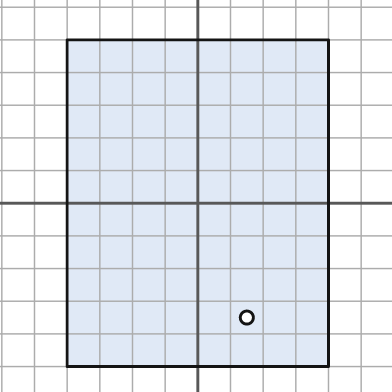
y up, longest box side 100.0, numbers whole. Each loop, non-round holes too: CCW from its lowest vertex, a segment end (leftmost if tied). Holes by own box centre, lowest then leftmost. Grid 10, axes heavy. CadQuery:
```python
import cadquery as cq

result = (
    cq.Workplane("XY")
    .moveTo(-40.0, -50.0)
    .lineTo(40.0, -50.0)
    .lineTo(40.0, 50.0)
    .lineTo(-40.0, 50.0)
    .close()
    .moveTo(15.0, -35.0)
    .circle(2.0)
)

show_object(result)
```